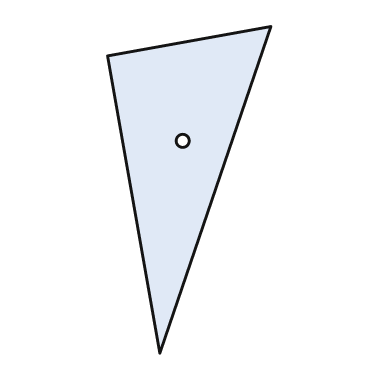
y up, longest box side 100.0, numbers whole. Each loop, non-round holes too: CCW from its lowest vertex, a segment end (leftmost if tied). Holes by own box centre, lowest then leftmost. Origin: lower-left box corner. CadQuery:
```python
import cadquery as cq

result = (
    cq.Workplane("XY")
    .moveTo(16.0, 0.0)
    .lineTo(50.0, 100.0)
    .lineTo(0.0, 91.0)
    .close()
    .moveTo(23.0, 65.0)
    .circle(2.0)
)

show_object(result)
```